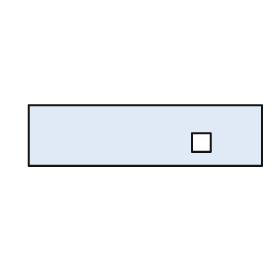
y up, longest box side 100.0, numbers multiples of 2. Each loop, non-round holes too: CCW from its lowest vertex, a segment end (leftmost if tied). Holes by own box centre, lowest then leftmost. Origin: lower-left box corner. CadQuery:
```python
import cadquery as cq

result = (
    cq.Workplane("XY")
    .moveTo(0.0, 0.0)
    .lineTo(100.0, 0.0)
    .lineTo(100.0, 26.0)
    .lineTo(0.0, 26.0)
    .close()
    .moveTo(70.0, 6.0)
    .lineTo(78.0, 6.0)
    .lineTo(78.0, 14.0)
    .lineTo(70.0, 14.0)
    .close()
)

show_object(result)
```